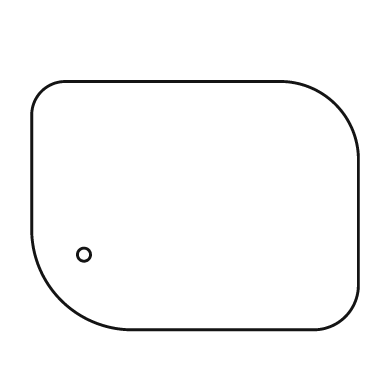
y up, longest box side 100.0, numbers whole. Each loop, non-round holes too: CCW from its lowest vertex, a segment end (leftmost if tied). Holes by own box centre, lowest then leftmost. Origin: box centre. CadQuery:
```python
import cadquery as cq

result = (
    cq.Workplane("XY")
    .moveTo(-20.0, -38.0)
    .lineTo(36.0, -38.0)
    .threePointArc((46.0, -34.0), (50.0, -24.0))
    .lineTo(50.0, 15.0)
    .threePointArc((43.0, 31.0), (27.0, 38.0))
    .lineTo(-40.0, 38.0)
    .threePointArc((-47.0, 35.0), (-50.0, 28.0))
    .lineTo(-50.0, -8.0)
    .threePointArc((-41.0, -29.0), (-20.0, -38.0))
    .close()
    .moveTo(-34.0, -15.0)
    .circle(2.0)
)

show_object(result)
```